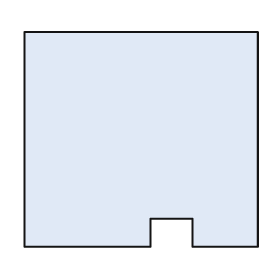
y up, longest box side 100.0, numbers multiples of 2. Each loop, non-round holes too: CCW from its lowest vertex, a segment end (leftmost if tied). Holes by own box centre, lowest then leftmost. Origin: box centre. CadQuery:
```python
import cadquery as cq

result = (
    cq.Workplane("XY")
    .moveTo(-50.0, -46.0)
    .lineTo(4.0, -46.0)
    .lineTo(4.0, -34.0)
    .lineTo(22.0, -34.0)
    .lineTo(22.0, -46.0)
    .lineTo(50.0, -46.0)
    .lineTo(50.0, 46.0)
    .lineTo(-50.0, 46.0)
    .close()
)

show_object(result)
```